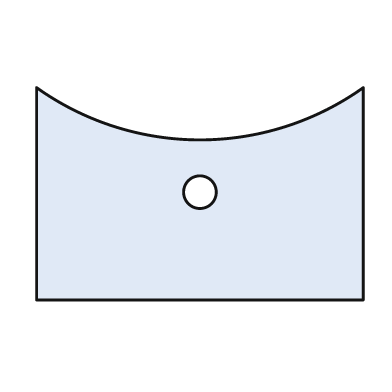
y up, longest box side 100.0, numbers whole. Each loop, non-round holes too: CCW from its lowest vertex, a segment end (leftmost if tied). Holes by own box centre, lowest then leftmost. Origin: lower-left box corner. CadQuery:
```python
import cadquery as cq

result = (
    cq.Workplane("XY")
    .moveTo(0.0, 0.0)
    .lineTo(100.0, 0.0)
    .lineTo(100.0, 65.0)
    .threePointArc((50.0, 49.0), (0.0, 65.0))
    .close()
    .moveTo(50.0, 33.0)
    .circle(5.0)
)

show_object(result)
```